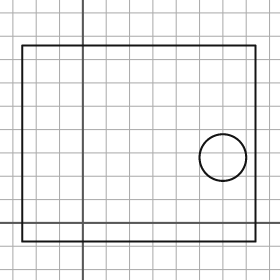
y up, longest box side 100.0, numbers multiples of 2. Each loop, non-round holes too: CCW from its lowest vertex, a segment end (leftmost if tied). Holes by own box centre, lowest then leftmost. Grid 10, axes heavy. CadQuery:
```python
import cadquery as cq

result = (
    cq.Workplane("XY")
    .moveTo(-26.0, -8.0)
    .lineTo(74.0, -8.0)
    .lineTo(74.0, 76.0)
    .lineTo(-26.0, 76.0)
    .close()
    .moveTo(60.0, 28.0)
    .circle(10.0)
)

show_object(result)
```